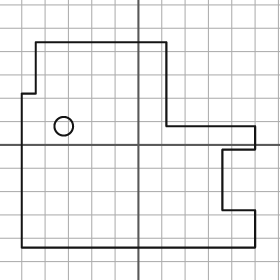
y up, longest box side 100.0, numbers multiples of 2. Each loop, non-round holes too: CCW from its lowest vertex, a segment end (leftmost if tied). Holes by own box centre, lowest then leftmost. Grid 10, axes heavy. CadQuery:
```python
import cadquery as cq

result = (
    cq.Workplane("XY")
    .moveTo(-50.0, -44.0)
    .lineTo(50.0, -44.0)
    .lineTo(50.0, -28.0)
    .lineTo(36.0, -28.0)
    .lineTo(36.0, -2.0)
    .lineTo(50.0, -2.0)
    .lineTo(50.0, 8.0)
    .lineTo(12.0, 8.0)
    .lineTo(12.0, 44.0)
    .lineTo(-44.0, 44.0)
    .lineTo(-44.0, 22.0)
    .lineTo(-50.0, 22.0)
    .close()
    .moveTo(-32.0, 8.0)
    .circle(4.0)
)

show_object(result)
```